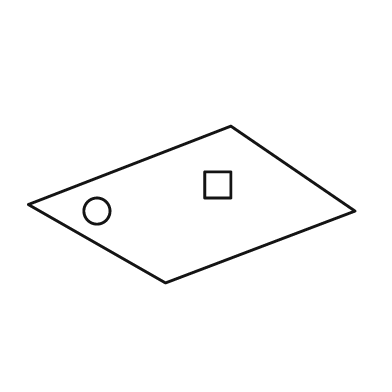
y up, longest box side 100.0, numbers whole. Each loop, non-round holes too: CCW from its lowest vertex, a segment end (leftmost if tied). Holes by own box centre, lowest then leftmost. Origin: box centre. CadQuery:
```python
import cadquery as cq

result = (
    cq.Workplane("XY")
    .moveTo(-8.0, -24.0)
    .lineTo(50.0, -2.0)
    .lineTo(12.0, 24.0)
    .lineTo(-50.0, 0.0)
    .close()
    .moveTo(-29.0, -2.0)
    .circle(4.0)
    .moveTo(4.0, 2.0)
    .lineTo(12.0, 2.0)
    .lineTo(12.0, 10.0)
    .lineTo(4.0, 10.0)
    .close()
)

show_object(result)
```